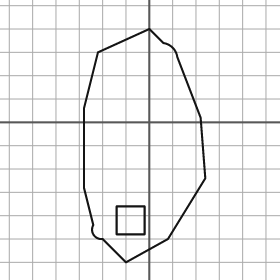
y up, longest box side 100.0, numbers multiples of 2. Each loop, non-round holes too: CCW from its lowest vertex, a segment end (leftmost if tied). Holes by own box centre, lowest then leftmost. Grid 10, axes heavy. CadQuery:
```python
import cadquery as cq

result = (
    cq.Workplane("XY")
    .moveTo(-10.0, -60.0)
    .lineTo(8.0, -50.0)
    .lineTo(24.0, -24.0)
    .lineTo(22.0, 2.0)
    .lineTo(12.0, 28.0)
    .threePointArc((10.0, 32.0), (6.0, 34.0))
    .lineTo(0.0, 40.0)
    .lineTo(-22.0, 30.0)
    .lineTo(-28.0, 6.0)
    .lineTo(-28.0, -28.0)
    .lineTo(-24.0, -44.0)
    .threePointArc((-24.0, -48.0), (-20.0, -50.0))
    .close()
    .moveTo(-14.0, -48.0)
    .lineTo(-2.0, -48.0)
    .lineTo(-2.0, -36.0)
    .lineTo(-14.0, -36.0)
    .close()
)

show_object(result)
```